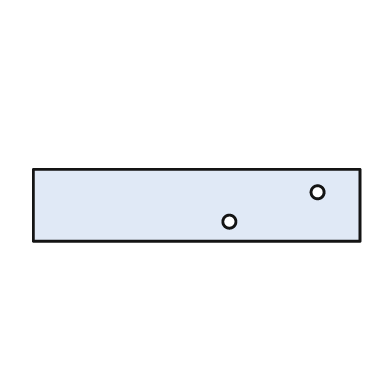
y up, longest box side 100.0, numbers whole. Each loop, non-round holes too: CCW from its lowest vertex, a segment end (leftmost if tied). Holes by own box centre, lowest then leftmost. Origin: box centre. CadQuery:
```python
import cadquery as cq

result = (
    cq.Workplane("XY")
    .moveTo(-50.0, -11.0)
    .lineTo(50.0, -11.0)
    .lineTo(50.0, 11.0)
    .lineTo(-50.0, 11.0)
    .close()
    .moveTo(10.0, -5.0)
    .circle(2.0)
    .moveTo(37.0, 4.0)
    .circle(2.0)
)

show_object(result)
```